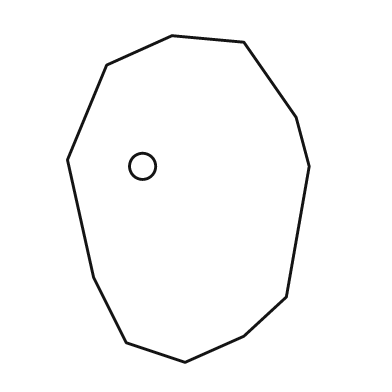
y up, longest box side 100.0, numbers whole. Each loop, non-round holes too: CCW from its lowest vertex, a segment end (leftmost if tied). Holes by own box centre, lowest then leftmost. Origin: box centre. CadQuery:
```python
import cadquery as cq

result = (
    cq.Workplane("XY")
    .moveTo(-1.0, -50.0)
    .lineTo(17.0, -42.0)
    .lineTo(30.0, -30.0)
    .lineTo(37.0, 10.0)
    .lineTo(33.0, 25.0)
    .lineTo(17.0, 48.0)
    .lineTo(-5.0, 50.0)
    .lineTo(-25.0, 41.0)
    .lineTo(-37.0, 12.0)
    .lineTo(-29.0, -24.0)
    .lineTo(-19.0, -44.0)
    .close()
    .moveTo(-14.0, 10.0)
    .circle(4.0)
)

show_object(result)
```